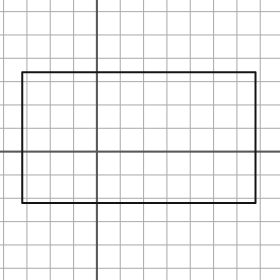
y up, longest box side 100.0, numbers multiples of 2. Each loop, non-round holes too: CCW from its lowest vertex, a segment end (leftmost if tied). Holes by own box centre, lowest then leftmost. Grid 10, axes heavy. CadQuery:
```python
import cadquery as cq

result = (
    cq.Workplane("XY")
    .moveTo(-32.0, -22.0)
    .lineTo(68.0, -22.0)
    .lineTo(68.0, 34.0)
    .lineTo(-32.0, 34.0)
    .close()
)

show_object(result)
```